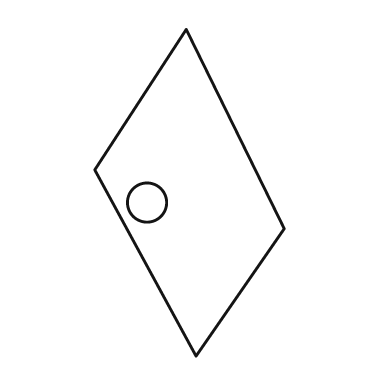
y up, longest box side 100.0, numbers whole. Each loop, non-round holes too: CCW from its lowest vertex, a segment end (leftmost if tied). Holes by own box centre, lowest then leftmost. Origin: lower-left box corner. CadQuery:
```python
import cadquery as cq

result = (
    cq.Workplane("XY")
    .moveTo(31.0, 0.0)
    .lineTo(58.0, 39.0)
    .lineTo(28.0, 100.0)
    .lineTo(0.0, 57.0)
    .close()
    .moveTo(16.0, 47.0)
    .circle(6.0)
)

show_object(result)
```